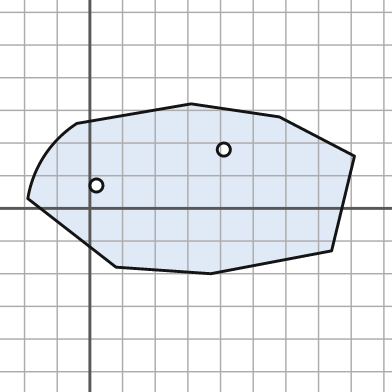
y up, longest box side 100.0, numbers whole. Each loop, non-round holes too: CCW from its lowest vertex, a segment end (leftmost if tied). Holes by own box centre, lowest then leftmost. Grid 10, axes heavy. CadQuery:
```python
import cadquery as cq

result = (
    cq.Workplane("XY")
    .moveTo(37.0, -20.0)
    .lineTo(74.0, -13.0)
    .lineTo(81.0, 16.0)
    .lineTo(58.0, 28.0)
    .lineTo(31.0, 32.0)
    .lineTo(-4.0, 26.0)
    .threePointArc((-14.0, 16.0), (-19.0, 3.0))
    .lineTo(8.0, -18.0)
    .close()
    .moveTo(2.0, 7.0)
    .circle(2.0)
    .moveTo(41.0, 18.0)
    .circle(2.0)
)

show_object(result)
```